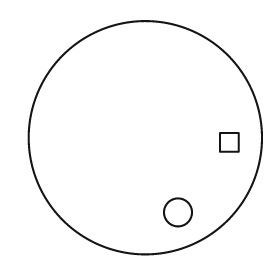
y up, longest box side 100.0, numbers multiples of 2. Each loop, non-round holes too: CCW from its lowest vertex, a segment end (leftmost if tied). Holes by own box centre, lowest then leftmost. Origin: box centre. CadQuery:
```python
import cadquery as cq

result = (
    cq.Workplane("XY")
    .moveTo(0.0, 0.0)
    .circle(50.0)
    .moveTo(14.0, -32.0)
    .circle(6.0)
    .moveTo(32.0, -6.0)
    .lineTo(40.0, -6.0)
    .lineTo(40.0, 2.0)
    .lineTo(32.0, 2.0)
    .close()
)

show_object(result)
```